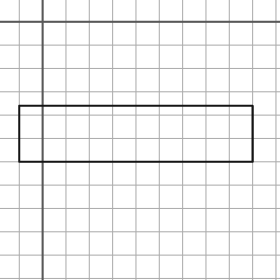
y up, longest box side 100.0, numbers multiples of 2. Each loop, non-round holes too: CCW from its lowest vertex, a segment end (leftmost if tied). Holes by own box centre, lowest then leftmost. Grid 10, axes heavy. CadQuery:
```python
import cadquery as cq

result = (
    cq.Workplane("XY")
    .moveTo(-10.0, -60.0)
    .lineTo(90.0, -60.0)
    .lineTo(90.0, -36.0)
    .lineTo(-10.0, -36.0)
    .close()
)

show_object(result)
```